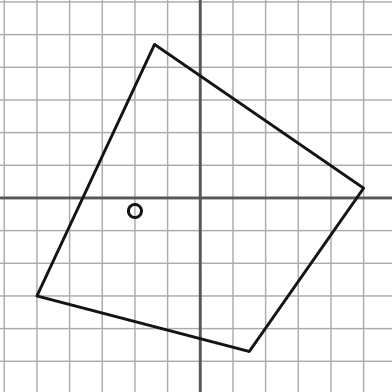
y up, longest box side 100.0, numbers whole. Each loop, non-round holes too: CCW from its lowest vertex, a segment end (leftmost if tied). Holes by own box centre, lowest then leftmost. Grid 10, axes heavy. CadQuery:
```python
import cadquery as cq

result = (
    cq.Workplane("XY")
    .moveTo(15.0, -47.0)
    .lineTo(50.0, 3.0)
    .lineTo(-14.0, 47.0)
    .lineTo(-50.0, -30.0)
    .close()
    .moveTo(-20.0, -4.0)
    .circle(2.0)
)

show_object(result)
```